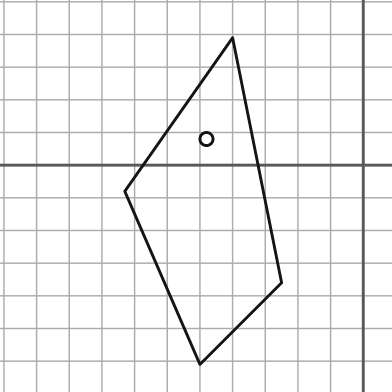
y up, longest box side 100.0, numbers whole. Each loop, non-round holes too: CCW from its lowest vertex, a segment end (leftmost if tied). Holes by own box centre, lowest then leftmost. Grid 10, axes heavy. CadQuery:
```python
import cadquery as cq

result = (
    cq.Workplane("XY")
    .moveTo(-50.0, -61.0)
    .lineTo(-25.0, -36.0)
    .lineTo(-40.0, 39.0)
    .lineTo(-73.0, -8.0)
    .close()
    .moveTo(-48.0, 8.0)
    .circle(2.0)
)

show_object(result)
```